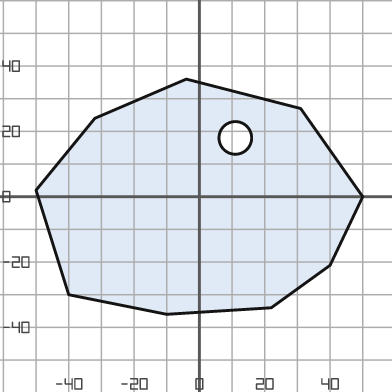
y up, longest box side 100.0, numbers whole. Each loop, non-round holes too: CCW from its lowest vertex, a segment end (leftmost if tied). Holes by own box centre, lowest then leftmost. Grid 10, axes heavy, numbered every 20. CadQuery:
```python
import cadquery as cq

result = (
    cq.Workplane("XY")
    .moveTo(-10.0, -36.0)
    .lineTo(22.0, -34.0)
    .lineTo(40.0, -21.0)
    .lineTo(50.0, 0.0)
    .lineTo(31.0, 27.0)
    .lineTo(-4.0, 36.0)
    .lineTo(-32.0, 24.0)
    .lineTo(-50.0, 2.0)
    .lineTo(-40.0, -30.0)
    .close()
    .moveTo(11.0, 18.0)
    .circle(5.0)
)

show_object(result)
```